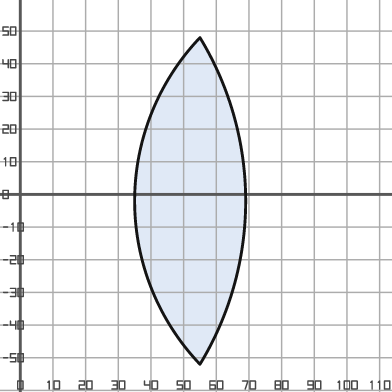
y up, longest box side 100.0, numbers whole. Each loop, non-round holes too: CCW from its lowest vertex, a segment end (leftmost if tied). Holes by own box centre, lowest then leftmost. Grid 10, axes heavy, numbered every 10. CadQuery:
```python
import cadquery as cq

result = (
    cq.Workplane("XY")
    .moveTo(55.0, -52.0)
    .threePointArc((69.0, -2.0), (55.0, 48.0))
    .threePointArc((35.0, -2.0), (55.0, -52.0))
    .close()
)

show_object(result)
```